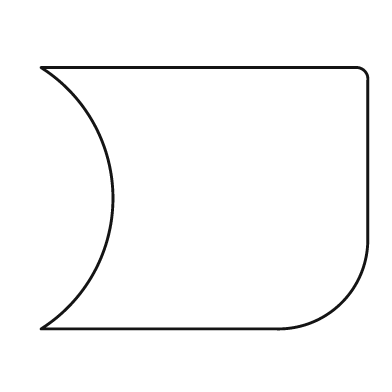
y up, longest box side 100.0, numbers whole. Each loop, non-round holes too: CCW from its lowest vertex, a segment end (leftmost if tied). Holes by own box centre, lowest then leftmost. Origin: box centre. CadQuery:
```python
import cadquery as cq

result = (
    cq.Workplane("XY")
    .moveTo(-50.0, -40.0)
    .lineTo(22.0, -40.0)
    .threePointArc((42.0, -32.0), (50.0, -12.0))
    .lineTo(50.0, 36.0)
    .threePointArc((49.0, 39.0), (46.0, 40.0))
    .lineTo(-50.0, 40.0)
    .threePointArc((-28.0, 0.0), (-50.0, -40.0))
    .close()
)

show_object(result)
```